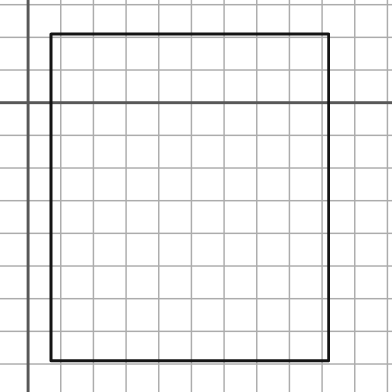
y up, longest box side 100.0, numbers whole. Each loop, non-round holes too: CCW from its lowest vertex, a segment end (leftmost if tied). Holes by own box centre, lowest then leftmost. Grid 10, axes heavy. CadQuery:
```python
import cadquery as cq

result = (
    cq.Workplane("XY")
    .moveTo(7.0, -79.0)
    .lineTo(92.0, -79.0)
    .lineTo(92.0, 21.0)
    .lineTo(7.0, 21.0)
    .close()
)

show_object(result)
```